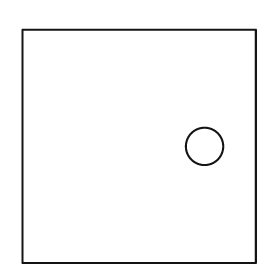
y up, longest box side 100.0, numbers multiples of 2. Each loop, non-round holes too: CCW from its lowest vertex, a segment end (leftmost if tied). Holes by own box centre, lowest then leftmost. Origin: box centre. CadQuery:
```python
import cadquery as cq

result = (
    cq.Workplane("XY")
    .moveTo(-50.0, -50.0)
    .lineTo(50.0, -50.0)
    .lineTo(50.0, 50.0)
    .lineTo(-50.0, 50.0)
    .close()
    .moveTo(28.0, 0.0)
    .circle(8.0)
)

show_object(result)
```